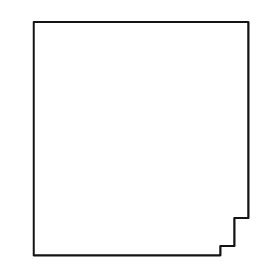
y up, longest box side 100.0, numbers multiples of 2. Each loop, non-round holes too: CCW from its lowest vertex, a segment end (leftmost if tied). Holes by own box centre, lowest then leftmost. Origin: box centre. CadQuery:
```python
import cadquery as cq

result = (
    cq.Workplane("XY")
    .moveTo(-46.0, -50.0)
    .lineTo(34.0, -50.0)
    .lineTo(34.0, -46.0)
    .lineTo(40.0, -46.0)
    .lineTo(40.0, -34.0)
    .lineTo(46.0, -34.0)
    .lineTo(46.0, 50.0)
    .lineTo(-46.0, 50.0)
    .close()
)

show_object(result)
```